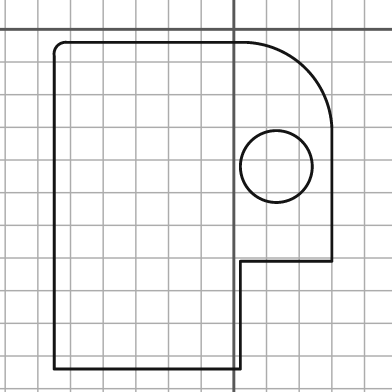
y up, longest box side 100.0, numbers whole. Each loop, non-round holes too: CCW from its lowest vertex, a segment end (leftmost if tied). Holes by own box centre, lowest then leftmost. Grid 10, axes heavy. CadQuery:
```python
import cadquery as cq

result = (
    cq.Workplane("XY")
    .moveTo(-55.0, -104.0)
    .lineTo(2.0, -104.0)
    .lineTo(2.0, -71.0)
    .lineTo(30.0, -71.0)
    .lineTo(30.0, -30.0)
    .threePointArc((22.0, -12.0), (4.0, -4.0))
    .lineTo(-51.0, -4.0)
    .threePointArc((-54.0, -5.0), (-55.0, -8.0))
    .close()
    .moveTo(13.0, -42.0)
    .circle(11.0)
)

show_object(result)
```